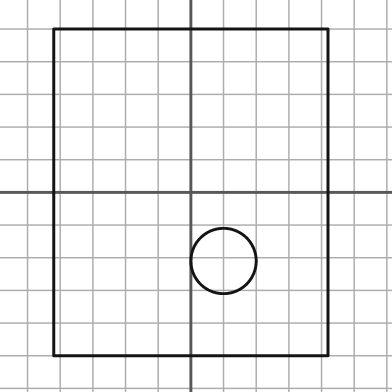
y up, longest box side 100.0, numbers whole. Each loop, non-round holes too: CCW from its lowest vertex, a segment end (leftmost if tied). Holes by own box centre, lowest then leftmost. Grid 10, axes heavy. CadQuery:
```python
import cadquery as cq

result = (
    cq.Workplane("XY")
    .moveTo(-42.0, -50.0)
    .lineTo(42.0, -50.0)
    .lineTo(42.0, 50.0)
    .lineTo(-42.0, 50.0)
    .close()
    .moveTo(10.0, -21.0)
    .circle(10.0)
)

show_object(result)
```